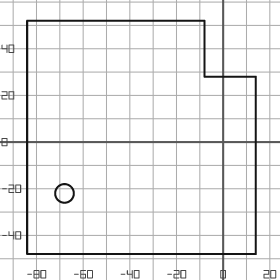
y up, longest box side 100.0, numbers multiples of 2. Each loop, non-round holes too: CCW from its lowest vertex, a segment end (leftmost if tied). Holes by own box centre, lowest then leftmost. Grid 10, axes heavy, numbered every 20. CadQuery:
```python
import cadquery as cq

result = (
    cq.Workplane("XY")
    .moveTo(-84.0, -48.0)
    .lineTo(14.0, -48.0)
    .lineTo(14.0, 28.0)
    .lineTo(-8.0, 28.0)
    .lineTo(-8.0, 52.0)
    .lineTo(-84.0, 52.0)
    .close()
    .moveTo(-68.0, -22.0)
    .circle(4.0)
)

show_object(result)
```